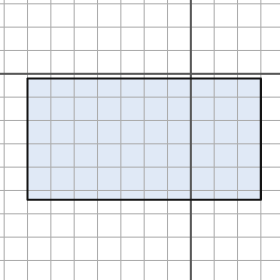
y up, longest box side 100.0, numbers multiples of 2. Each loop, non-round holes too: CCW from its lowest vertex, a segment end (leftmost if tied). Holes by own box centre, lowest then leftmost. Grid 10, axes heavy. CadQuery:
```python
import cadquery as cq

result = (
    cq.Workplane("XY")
    .moveTo(-70.0, -54.0)
    .lineTo(30.0, -54.0)
    .lineTo(30.0, -2.0)
    .lineTo(-70.0, -2.0)
    .close()
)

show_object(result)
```